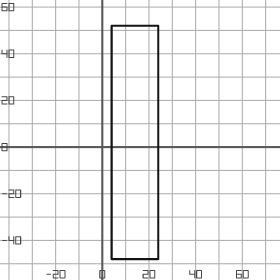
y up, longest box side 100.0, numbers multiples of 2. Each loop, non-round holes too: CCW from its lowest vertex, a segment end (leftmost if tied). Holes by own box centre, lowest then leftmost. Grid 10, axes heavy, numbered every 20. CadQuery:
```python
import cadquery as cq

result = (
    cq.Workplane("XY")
    .moveTo(4.0, -48.0)
    .lineTo(24.0, -48.0)
    .lineTo(24.0, 52.0)
    .lineTo(4.0, 52.0)
    .close()
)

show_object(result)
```